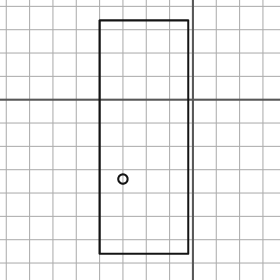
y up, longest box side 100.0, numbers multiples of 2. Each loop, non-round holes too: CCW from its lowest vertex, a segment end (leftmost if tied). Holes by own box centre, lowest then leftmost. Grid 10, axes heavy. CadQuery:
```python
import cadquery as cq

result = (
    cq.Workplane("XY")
    .moveTo(-40.0, -66.0)
    .lineTo(-2.0, -66.0)
    .lineTo(-2.0, 34.0)
    .lineTo(-40.0, 34.0)
    .close()
    .moveTo(-30.0, -34.0)
    .circle(2.0)
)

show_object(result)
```